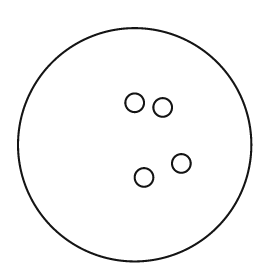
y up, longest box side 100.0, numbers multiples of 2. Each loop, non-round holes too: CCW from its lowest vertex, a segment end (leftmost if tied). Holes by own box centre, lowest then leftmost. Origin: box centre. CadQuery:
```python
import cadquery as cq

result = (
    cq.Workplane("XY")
    .moveTo(0.0, 0.0)
    .circle(50.0)
    .moveTo(4.0, -14.0)
    .circle(4.0)
    .moveTo(20.0, -8.0)
    .circle(4.0)
    .moveTo(12.0, 16.0)
    .circle(4.0)
    .moveTo(0.0, 18.0)
    .circle(4.0)
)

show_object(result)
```